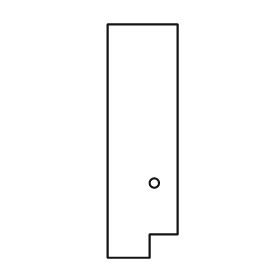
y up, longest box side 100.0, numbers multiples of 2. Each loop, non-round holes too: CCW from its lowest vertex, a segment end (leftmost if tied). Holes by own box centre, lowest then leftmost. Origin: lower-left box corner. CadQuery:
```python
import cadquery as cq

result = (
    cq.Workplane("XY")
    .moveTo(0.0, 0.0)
    .lineTo(18.0, 0.0)
    .lineTo(18.0, 10.0)
    .lineTo(30.0, 10.0)
    .lineTo(30.0, 100.0)
    .lineTo(0.0, 100.0)
    .close()
    .moveTo(20.0, 32.0)
    .circle(2.0)
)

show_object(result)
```